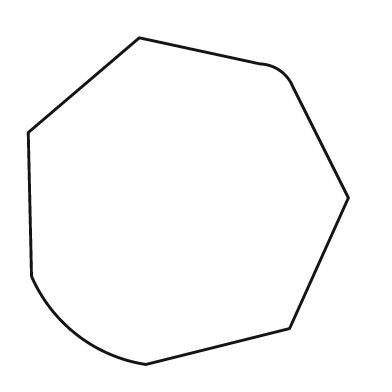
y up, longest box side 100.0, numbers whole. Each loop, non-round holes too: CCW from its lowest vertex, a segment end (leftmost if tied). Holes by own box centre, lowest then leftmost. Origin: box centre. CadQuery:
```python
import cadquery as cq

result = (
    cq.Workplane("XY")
    .moveTo(-13.0, -50.0)
    .lineTo(31.0, -39.0)
    .lineTo(49.0, 1.0)
    .lineTo(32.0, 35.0)
    .threePointArc((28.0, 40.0), (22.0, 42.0))
    .lineTo(-15.0, 50.0)
    .lineTo(-49.0, 21.0)
    .lineTo(-48.0, -23.0)
    .threePointArc((-34.0, -41.0), (-13.0, -50.0))
    .close()
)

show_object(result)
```